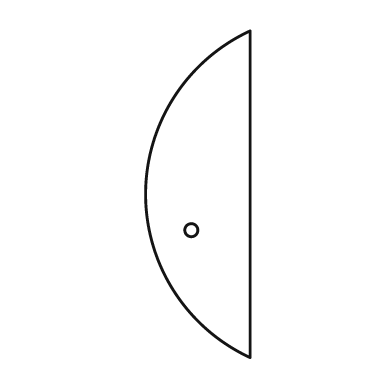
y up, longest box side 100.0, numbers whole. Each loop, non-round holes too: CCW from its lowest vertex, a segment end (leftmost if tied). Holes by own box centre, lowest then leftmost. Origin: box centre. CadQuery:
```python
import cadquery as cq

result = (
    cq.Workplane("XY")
    .moveTo(16.0, -50.0)
    .lineTo(16.0, 50.0)
    .threePointArc((-16.0, 0.0), (16.0, -50.0))
    .close()
    .moveTo(-2.0, -11.0)
    .circle(2.0)
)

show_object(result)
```